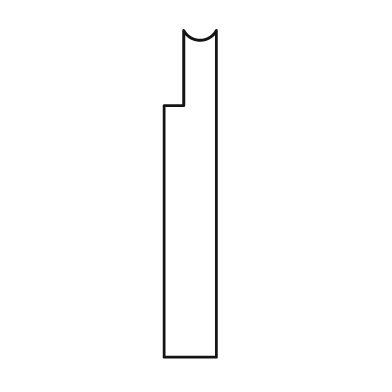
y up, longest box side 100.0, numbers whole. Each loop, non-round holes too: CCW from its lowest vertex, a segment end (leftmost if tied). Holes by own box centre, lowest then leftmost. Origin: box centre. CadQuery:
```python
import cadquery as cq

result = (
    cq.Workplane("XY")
    .moveTo(-8.0, -50.0)
    .lineTo(8.0, -50.0)
    .lineTo(8.0, 50.0)
    .threePointArc((3.0, 47.0), (-2.0, 50.0))
    .lineTo(-2.0, 27.0)
    .lineTo(-8.0, 27.0)
    .close()
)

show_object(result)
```